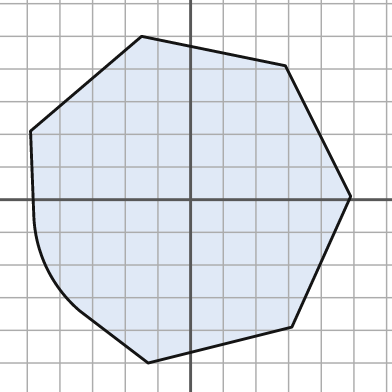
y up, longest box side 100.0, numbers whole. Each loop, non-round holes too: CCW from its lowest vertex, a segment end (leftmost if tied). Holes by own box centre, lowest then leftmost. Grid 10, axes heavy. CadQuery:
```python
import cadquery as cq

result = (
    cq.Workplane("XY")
    .moveTo(-13.0, -50.0)
    .lineTo(31.0, -39.0)
    .lineTo(49.0, 1.0)
    .lineTo(29.0, 41.0)
    .lineTo(-15.0, 50.0)
    .lineTo(-49.0, 21.0)
    .lineTo(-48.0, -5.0)
    .threePointArc((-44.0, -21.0), (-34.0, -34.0))
    .close()
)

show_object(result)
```